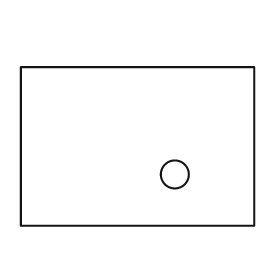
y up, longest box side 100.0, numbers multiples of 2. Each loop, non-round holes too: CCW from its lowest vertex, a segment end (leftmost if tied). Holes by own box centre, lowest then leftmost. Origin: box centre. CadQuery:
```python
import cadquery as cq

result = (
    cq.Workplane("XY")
    .moveTo(-50.0, -34.0)
    .lineTo(50.0, -34.0)
    .lineTo(50.0, 34.0)
    .lineTo(-50.0, 34.0)
    .close()
    .moveTo(16.0, -12.0)
    .circle(6.0)
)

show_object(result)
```